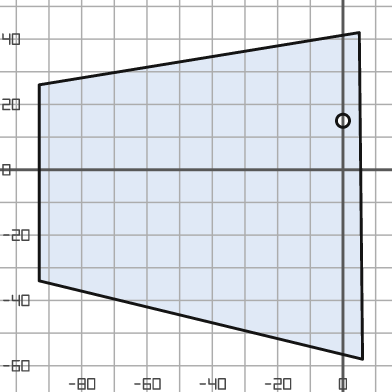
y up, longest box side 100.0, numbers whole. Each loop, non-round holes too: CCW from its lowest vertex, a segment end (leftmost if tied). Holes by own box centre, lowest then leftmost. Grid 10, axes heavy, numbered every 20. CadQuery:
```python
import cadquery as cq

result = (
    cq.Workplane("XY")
    .moveTo(6.0, -58.0)
    .lineTo(5.0, 42.0)
    .lineTo(-93.0, 26.0)
    .lineTo(-93.0, -34.0)
    .close()
    .moveTo(0.0, 15.0)
    .circle(2.0)
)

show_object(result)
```